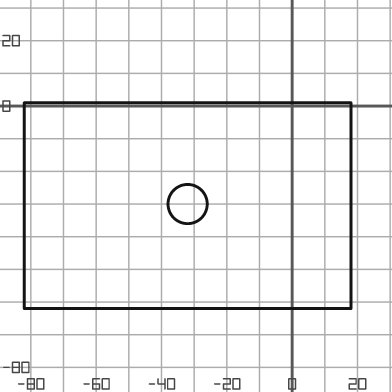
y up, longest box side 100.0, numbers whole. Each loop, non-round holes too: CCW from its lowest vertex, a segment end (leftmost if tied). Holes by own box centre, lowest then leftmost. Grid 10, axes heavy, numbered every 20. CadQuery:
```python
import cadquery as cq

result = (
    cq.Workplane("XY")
    .moveTo(-82.0, -62.0)
    .lineTo(18.0, -62.0)
    .lineTo(18.0, 1.0)
    .lineTo(-82.0, 1.0)
    .close()
    .moveTo(-32.0, -30.0)
    .circle(6.0)
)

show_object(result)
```